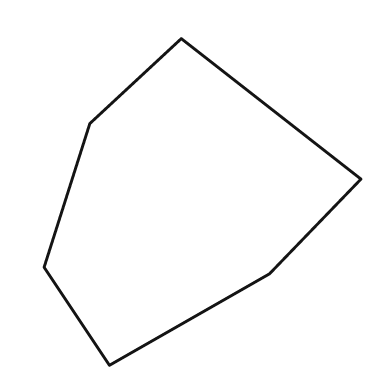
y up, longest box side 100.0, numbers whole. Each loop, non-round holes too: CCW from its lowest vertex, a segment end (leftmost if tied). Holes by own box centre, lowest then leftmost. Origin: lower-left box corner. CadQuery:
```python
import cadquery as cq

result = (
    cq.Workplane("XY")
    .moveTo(20.0, 0.0)
    .lineTo(69.0, 28.0)
    .lineTo(97.0, 57.0)
    .lineTo(42.0, 100.0)
    .lineTo(14.0, 74.0)
    .lineTo(0.0, 30.0)
    .close()
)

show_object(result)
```